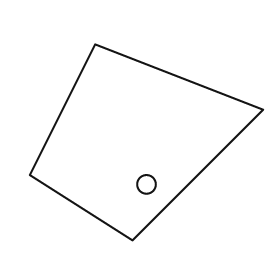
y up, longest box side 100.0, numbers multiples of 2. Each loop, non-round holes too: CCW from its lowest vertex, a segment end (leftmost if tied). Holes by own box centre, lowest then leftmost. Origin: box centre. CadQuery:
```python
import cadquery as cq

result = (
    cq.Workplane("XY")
    .moveTo(-6.0, -42.0)
    .lineTo(50.0, 14.0)
    .lineTo(-22.0, 42.0)
    .lineTo(-50.0, -14.0)
    .close()
    .moveTo(0.0, -18.0)
    .circle(4.0)
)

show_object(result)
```